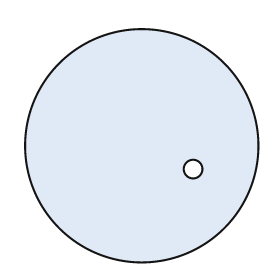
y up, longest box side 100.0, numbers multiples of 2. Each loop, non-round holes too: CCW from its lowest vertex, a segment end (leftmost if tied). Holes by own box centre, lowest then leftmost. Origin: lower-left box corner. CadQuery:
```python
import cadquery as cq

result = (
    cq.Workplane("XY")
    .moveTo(50.0, 50.0)
    .circle(50.0)
    .moveTo(72.0, 40.0)
    .circle(4.0)
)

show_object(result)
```